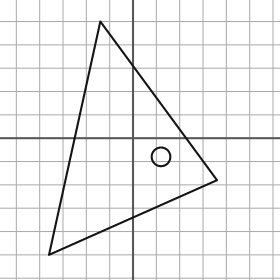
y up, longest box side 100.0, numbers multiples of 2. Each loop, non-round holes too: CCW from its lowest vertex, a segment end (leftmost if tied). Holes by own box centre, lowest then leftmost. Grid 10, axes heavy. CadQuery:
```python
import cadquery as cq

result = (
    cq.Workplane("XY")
    .moveTo(-36.0, -50.0)
    .lineTo(36.0, -18.0)
    .lineTo(-14.0, 50.0)
    .close()
    .moveTo(12.0, -8.0)
    .circle(4.0)
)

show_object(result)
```